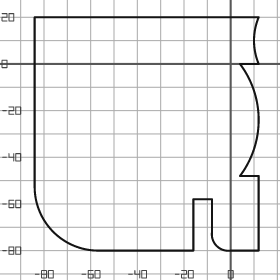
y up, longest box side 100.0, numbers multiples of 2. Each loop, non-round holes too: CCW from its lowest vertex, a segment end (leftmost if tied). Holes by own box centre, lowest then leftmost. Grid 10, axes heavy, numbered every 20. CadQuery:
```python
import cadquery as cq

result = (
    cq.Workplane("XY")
    .moveTo(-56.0, -80.0)
    .lineTo(-16.0, -80.0)
    .lineTo(-16.0, -58.0)
    .lineTo(-8.0, -58.0)
    .lineTo(-8.0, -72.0)
    .threePointArc((-6.0, -78.0), (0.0, -80.0))
    .lineTo(12.0, -80.0)
    .lineTo(12.0, -48.0)
    .lineTo(4.0, -48.0)
    .threePointArc((12.0, -24.0), (4.0, 0.0))
    .lineTo(12.0, 0.0)
    .threePointArc((10.0, 10.0), (12.0, 20.0))
    .lineTo(-84.0, 20.0)
    .lineTo(-84.0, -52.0)
    .threePointArc((-76.0, -72.0), (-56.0, -80.0))
    .close()
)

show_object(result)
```